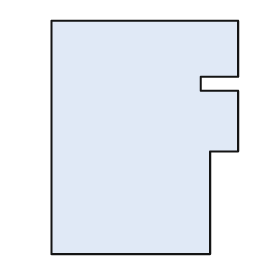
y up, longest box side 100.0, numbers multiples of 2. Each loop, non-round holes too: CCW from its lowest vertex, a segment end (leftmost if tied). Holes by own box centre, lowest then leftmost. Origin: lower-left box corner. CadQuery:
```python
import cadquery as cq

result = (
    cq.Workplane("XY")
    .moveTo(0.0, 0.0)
    .lineTo(68.0, 0.0)
    .lineTo(68.0, 44.0)
    .lineTo(80.0, 44.0)
    .lineTo(80.0, 70.0)
    .lineTo(64.0, 70.0)
    .lineTo(64.0, 76.0)
    .lineTo(80.0, 76.0)
    .lineTo(80.0, 100.0)
    .lineTo(0.0, 100.0)
    .close()
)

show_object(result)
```